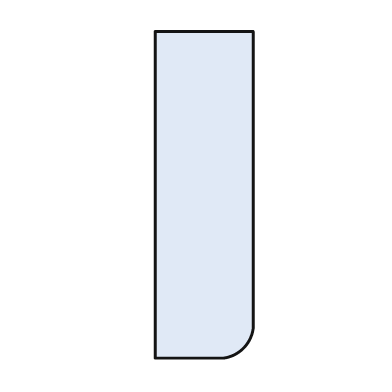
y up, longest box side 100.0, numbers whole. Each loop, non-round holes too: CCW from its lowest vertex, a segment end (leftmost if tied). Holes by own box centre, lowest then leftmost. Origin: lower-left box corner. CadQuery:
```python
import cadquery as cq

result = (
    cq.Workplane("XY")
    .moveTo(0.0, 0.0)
    .lineTo(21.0, 0.0)
    .threePointArc((27.0, 3.0), (30.0, 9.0))
    .lineTo(30.0, 100.0)
    .lineTo(0.0, 100.0)
    .close()
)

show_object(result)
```